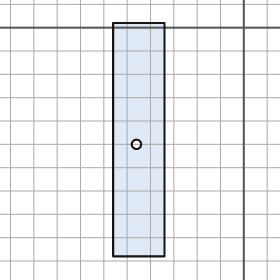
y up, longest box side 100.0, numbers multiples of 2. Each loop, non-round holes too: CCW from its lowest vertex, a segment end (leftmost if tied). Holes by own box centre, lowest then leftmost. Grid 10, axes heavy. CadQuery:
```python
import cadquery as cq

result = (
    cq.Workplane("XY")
    .moveTo(-56.0, -98.0)
    .lineTo(-34.0, -98.0)
    .lineTo(-34.0, 2.0)
    .lineTo(-56.0, 2.0)
    .close()
    .moveTo(-46.0, -50.0)
    .circle(2.0)
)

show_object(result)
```